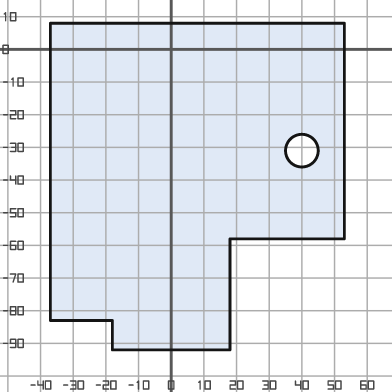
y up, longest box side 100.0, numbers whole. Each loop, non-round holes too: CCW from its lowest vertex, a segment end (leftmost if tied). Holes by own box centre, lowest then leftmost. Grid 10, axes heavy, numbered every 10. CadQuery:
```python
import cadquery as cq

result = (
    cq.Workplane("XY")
    .moveTo(-18.0, -92.0)
    .lineTo(18.0, -92.0)
    .lineTo(18.0, -58.0)
    .lineTo(53.0, -58.0)
    .lineTo(53.0, 8.0)
    .lineTo(-37.0, 8.0)
    .lineTo(-37.0, -83.0)
    .lineTo(-18.0, -83.0)
    .close()
    .moveTo(40.0, -31.0)
    .circle(5.0)
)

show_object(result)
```